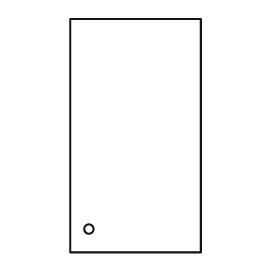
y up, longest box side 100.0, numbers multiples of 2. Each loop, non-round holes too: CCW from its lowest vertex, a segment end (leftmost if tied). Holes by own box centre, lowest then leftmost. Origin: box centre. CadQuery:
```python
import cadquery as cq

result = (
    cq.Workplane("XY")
    .moveTo(-28.0, -50.0)
    .lineTo(28.0, -50.0)
    .lineTo(28.0, 50.0)
    .lineTo(-28.0, 50.0)
    .close()
    .moveTo(-20.0, -40.0)
    .circle(2.0)
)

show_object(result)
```